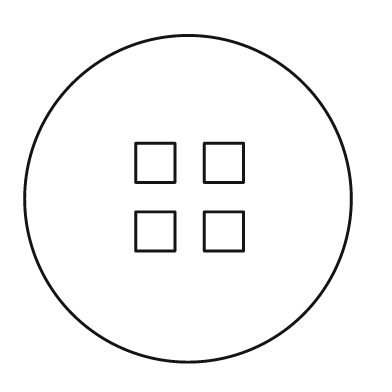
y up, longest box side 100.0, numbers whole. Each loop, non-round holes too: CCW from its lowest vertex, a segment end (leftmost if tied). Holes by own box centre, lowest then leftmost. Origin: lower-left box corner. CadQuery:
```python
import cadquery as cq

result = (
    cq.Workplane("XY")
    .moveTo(50.0, 50.0)
    .circle(50.0)
    .moveTo(34.0, 34.0)
    .lineTo(46.0, 34.0)
    .lineTo(46.0, 46.0)
    .lineTo(34.0, 46.0)
    .close()
    .moveTo(55.0, 34.0)
    .lineTo(67.0, 34.0)
    .lineTo(67.0, 46.0)
    .lineTo(55.0, 46.0)
    .close()
    .moveTo(34.0, 55.0)
    .lineTo(46.0, 55.0)
    .lineTo(46.0, 67.0)
    .lineTo(34.0, 67.0)
    .close()
    .moveTo(55.0, 55.0)
    .lineTo(67.0, 55.0)
    .lineTo(67.0, 67.0)
    .lineTo(55.0, 67.0)
    .close()
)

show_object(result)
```